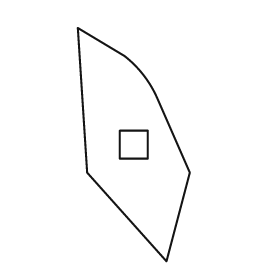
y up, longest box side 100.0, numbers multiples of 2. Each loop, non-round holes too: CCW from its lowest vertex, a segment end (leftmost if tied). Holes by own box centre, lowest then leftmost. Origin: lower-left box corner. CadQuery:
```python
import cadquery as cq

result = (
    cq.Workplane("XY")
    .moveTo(38.0, 0.0)
    .lineTo(48.0, 38.0)
    .lineTo(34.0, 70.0)
    .threePointArc((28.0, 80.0), (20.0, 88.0))
    .lineTo(0.0, 100.0)
    .lineTo(4.0, 38.0)
    .close()
    .moveTo(18.0, 44.0)
    .lineTo(30.0, 44.0)
    .lineTo(30.0, 56.0)
    .lineTo(18.0, 56.0)
    .close()
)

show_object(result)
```